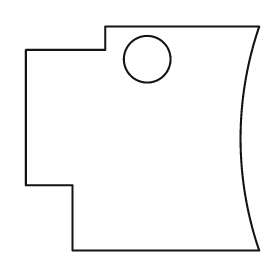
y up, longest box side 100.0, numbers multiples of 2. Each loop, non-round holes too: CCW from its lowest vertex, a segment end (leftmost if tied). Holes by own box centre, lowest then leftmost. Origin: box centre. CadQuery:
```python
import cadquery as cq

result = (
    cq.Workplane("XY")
    .moveTo(-30.0, -48.0)
    .lineTo(50.0, -48.0)
    .threePointArc((42.0, 0.0), (50.0, 48.0))
    .lineTo(-16.0, 48.0)
    .lineTo(-16.0, 38.0)
    .lineTo(-50.0, 38.0)
    .lineTo(-50.0, -20.0)
    .lineTo(-30.0, -20.0)
    .close()
    .moveTo(2.0, 34.0)
    .circle(10.0)
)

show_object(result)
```